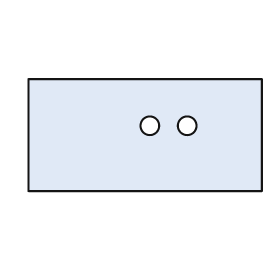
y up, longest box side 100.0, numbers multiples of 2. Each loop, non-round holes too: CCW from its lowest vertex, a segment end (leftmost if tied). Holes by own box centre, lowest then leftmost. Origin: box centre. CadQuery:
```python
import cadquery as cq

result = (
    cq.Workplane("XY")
    .moveTo(-50.0, -24.0)
    .lineTo(50.0, -24.0)
    .lineTo(50.0, 24.0)
    .lineTo(-50.0, 24.0)
    .close()
    .moveTo(2.0, 4.0)
    .circle(4.0)
    .moveTo(18.0, 4.0)
    .circle(4.0)
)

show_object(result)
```